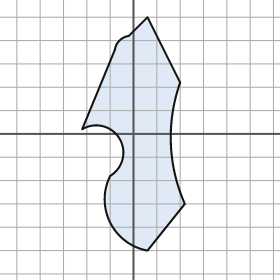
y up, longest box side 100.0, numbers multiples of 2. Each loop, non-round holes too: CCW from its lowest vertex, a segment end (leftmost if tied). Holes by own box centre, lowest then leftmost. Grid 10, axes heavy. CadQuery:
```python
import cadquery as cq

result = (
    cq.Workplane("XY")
    .moveTo(6.0, -50.0)
    .lineTo(22.0, -30.0)
    .threePointArc((16.0, -4.0), (20.0, 22.0))
    .lineTo(6.0, 50.0)
    .lineTo(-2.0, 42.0)
    .threePointArc((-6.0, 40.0), (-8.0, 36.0))
    .lineTo(-22.0, 2.0)
    .threePointArc((-6.0, -2.0), (-10.0, -18.0))
    .threePointArc((-10.0, -38.0), (6.0, -50.0))
    .close()
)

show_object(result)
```